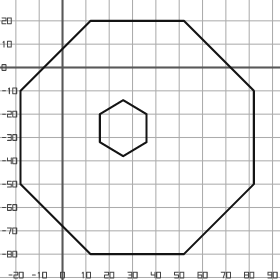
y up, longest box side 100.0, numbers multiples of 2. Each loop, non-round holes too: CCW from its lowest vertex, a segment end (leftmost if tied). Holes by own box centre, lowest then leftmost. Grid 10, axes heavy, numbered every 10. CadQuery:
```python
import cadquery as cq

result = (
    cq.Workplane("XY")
    .moveTo(12.0, -80.0)
    .lineTo(52.0, -80.0)
    .lineTo(82.0, -50.0)
    .lineTo(82.0, -10.0)
    .lineTo(52.0, 20.0)
    .lineTo(12.0, 20.0)
    .lineTo(-18.0, -10.0)
    .lineTo(-18.0, -50.0)
    .close()
    .moveTo(26.0, -38.0)
    .lineTo(36.0, -32.0)
    .lineTo(36.0, -20.0)
    .lineTo(26.0, -14.0)
    .lineTo(16.0, -20.0)
    .lineTo(16.0, -32.0)
    .close()
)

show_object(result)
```